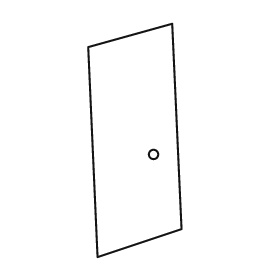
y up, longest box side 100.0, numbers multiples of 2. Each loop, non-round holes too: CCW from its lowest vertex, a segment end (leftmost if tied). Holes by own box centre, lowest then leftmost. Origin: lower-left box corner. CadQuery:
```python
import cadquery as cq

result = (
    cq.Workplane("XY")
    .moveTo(4.0, 0.0)
    .lineTo(40.0, 12.0)
    .lineTo(36.0, 100.0)
    .lineTo(0.0, 90.0)
    .close()
    .moveTo(28.0, 44.0)
    .circle(2.0)
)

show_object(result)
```